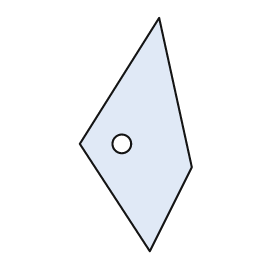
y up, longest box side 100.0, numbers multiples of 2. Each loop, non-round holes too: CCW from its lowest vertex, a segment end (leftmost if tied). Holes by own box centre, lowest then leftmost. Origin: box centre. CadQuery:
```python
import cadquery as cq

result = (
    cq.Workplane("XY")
    .moveTo(6.0, -50.0)
    .lineTo(24.0, -14.0)
    .lineTo(10.0, 50.0)
    .lineTo(-24.0, -4.0)
    .close()
    .moveTo(-6.0, -4.0)
    .circle(4.0)
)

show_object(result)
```